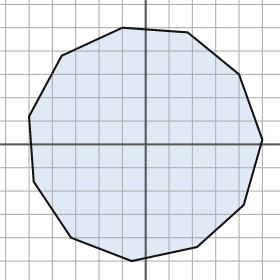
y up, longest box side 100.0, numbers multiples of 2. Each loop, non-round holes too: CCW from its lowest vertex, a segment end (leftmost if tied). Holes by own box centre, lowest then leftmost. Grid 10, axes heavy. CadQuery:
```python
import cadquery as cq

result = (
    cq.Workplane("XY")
    .moveTo(-6.0, -50.0)
    .lineTo(22.0, -44.0)
    .lineTo(42.0, -26.0)
    .lineTo(50.0, 2.0)
    .lineTo(40.0, 30.0)
    .lineTo(18.0, 48.0)
    .lineTo(-10.0, 50.0)
    .lineTo(-36.0, 38.0)
    .lineTo(-50.0, 12.0)
    .lineTo(-48.0, -16.0)
    .lineTo(-32.0, -40.0)
    .close()
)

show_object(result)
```